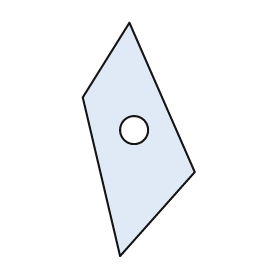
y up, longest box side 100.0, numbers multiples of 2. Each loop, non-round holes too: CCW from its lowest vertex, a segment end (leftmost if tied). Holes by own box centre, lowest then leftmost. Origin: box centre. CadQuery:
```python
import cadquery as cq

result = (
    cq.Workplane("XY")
    .moveTo(-8.0, -50.0)
    .lineTo(24.0, -14.0)
    .lineTo(-4.0, 50.0)
    .lineTo(-24.0, 18.0)
    .close()
    .moveTo(-2.0, 4.0)
    .circle(6.0)
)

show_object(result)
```